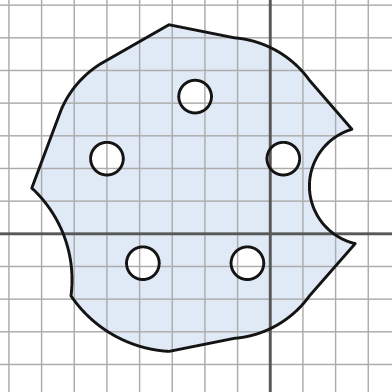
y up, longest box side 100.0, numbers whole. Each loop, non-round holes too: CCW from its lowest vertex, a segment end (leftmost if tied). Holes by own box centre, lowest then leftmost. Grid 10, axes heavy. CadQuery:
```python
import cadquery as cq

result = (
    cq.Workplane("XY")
    .moveTo(-31.0, -36.0)
    .lineTo(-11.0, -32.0)
    .threePointArc((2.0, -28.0), (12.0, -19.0))
    .lineTo(26.0, -3.0)
    .threePointArc((12.0, 14.0), (25.0, 32.0))
    .lineTo(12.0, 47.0)
    .threePointArc((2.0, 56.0), (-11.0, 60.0))
    .lineTo(-31.0, 64.0)
    .lineTo(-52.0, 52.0)
    .threePointArc((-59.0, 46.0), (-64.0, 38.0))
    .lineTo(-73.0, 14.0)
    .threePointArc((-63.0, -1.0), (-61.0, -19.0))
    .threePointArc((-48.0, -31.0), (-31.0, -36.0))
    .close()
    .moveTo(-39.0, -9.0)
    .circle(5.0)
    .moveTo(-7.0, -9.0)
    .circle(5.0)
    .moveTo(-50.0, 23.0)
    .circle(5.0)
    .moveTo(4.0, 23.0)
    .circle(5.0)
    .moveTo(-23.0, 42.0)
    .circle(5.0)
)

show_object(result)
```